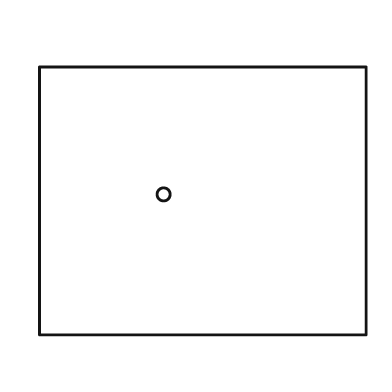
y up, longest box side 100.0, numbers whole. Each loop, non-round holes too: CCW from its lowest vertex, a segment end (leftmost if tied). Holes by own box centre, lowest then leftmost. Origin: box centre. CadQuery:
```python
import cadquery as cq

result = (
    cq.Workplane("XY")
    .moveTo(-50.0, -41.0)
    .lineTo(50.0, -41.0)
    .lineTo(50.0, 41.0)
    .lineTo(-50.0, 41.0)
    .close()
    .moveTo(-12.0, 2.0)
    .circle(2.0)
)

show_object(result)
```